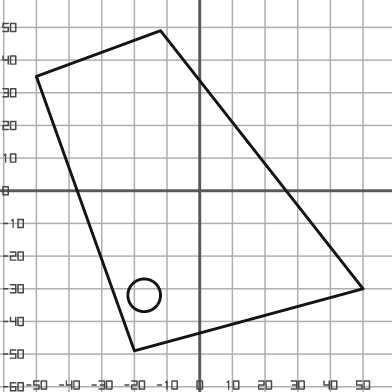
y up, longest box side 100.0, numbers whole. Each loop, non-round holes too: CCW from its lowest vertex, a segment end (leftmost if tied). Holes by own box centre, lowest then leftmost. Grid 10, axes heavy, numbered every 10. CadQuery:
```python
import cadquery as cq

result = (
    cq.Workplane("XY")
    .moveTo(-20.0, -49.0)
    .lineTo(50.0, -30.0)
    .lineTo(-12.0, 49.0)
    .lineTo(-50.0, 35.0)
    .close()
    .moveTo(-17.0, -32.0)
    .circle(5.0)
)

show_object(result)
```